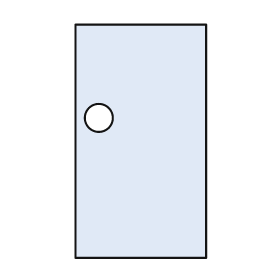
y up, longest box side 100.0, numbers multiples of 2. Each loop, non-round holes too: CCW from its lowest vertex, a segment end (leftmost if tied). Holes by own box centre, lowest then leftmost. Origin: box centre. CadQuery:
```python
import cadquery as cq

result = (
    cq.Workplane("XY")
    .moveTo(-28.0, -50.0)
    .lineTo(28.0, -50.0)
    .lineTo(28.0, 50.0)
    .lineTo(-28.0, 50.0)
    .close()
    .moveTo(-18.0, 10.0)
    .circle(6.0)
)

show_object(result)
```